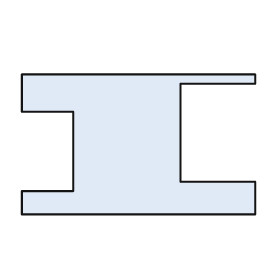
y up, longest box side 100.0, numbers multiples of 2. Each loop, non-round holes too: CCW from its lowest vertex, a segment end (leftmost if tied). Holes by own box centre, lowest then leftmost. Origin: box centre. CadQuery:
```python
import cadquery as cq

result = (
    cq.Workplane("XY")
    .moveTo(-50.0, -30.0)
    .lineTo(50.0, -30.0)
    .lineTo(50.0, -16.0)
    .lineTo(18.0, -16.0)
    .lineTo(18.0, 26.0)
    .lineTo(50.0, 26.0)
    .lineTo(50.0, 30.0)
    .lineTo(-50.0, 30.0)
    .lineTo(-50.0, 14.0)
    .lineTo(-28.0, 14.0)
    .lineTo(-28.0, -20.0)
    .lineTo(-50.0, -20.0)
    .close()
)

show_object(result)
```